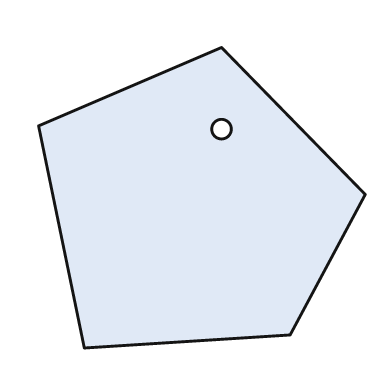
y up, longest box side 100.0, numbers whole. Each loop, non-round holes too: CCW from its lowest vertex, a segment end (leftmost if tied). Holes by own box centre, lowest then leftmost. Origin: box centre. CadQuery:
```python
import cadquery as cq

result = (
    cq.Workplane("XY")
    .moveTo(-36.0, -46.0)
    .lineTo(27.0, -42.0)
    .lineTo(50.0, 1.0)
    .lineTo(6.0, 46.0)
    .lineTo(-50.0, 22.0)
    .close()
    .moveTo(6.0, 21.0)
    .circle(3.0)
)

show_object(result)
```